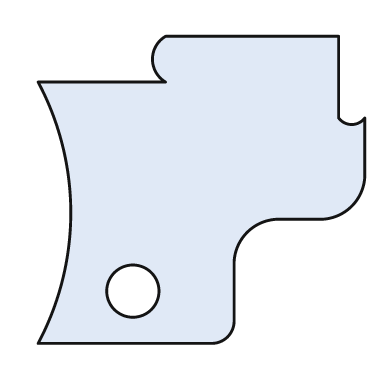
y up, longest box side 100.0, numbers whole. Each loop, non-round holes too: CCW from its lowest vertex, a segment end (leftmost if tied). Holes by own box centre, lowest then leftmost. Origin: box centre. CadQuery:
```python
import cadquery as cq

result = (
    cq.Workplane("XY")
    .moveTo(-50.0, -47.0)
    .lineTo(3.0, -47.0)
    .threePointArc((8.0, -45.0), (10.0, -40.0))
    .lineTo(10.0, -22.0)
    .threePointArc((14.0, -13.0), (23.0, -9.0))
    .lineTo(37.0, -9.0)
    .threePointArc((46.0, -5.0), (50.0, 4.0))
    .lineTo(50.0, 22.0)
    .threePointArc((46.0, 20.0), (42.0, 22.0))
    .lineTo(42.0, 47.0)
    .lineTo(-11.0, 47.0)
    .threePointArc((-15.0, 40.0), (-11.0, 33.0))
    .lineTo(-50.0, 33.0)
    .threePointArc((-40.0, -7.0), (-50.0, -47.0))
    .close()
    .moveTo(-21.0, -31.0)
    .circle(8.0)
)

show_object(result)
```